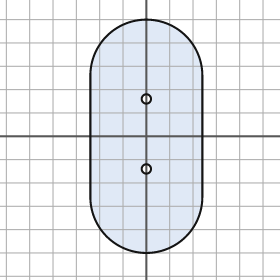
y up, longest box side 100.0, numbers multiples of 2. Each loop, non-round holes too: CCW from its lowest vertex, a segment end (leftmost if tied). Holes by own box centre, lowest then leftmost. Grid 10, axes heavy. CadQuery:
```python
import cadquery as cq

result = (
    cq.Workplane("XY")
    .moveTo(-24.0, -26.0)
    .threePointArc((0.0, -50.0), (24.0, -26.0))
    .lineTo(24.0, 26.0)
    .threePointArc((0.0, 50.0), (-24.0, 26.0))
    .close()
    .moveTo(0.0, -14.0)
    .circle(2.0)
    .moveTo(0.0, 16.0)
    .circle(2.0)
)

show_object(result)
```